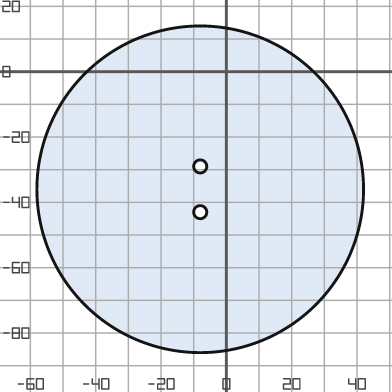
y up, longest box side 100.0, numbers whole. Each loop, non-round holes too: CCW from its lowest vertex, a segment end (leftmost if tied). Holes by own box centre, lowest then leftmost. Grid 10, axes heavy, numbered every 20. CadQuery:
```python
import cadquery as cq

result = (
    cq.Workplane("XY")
    .moveTo(-8.0, -36.0)
    .circle(50.0)
    .moveTo(-8.0, -43.0)
    .circle(2.0)
    .moveTo(-8.0, -29.0)
    .circle(2.0)
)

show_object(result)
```